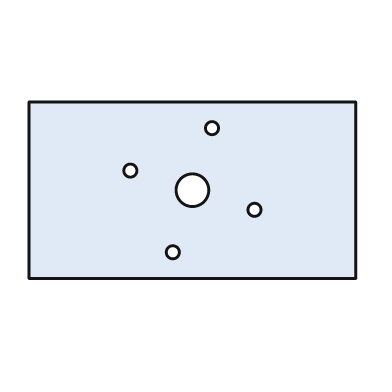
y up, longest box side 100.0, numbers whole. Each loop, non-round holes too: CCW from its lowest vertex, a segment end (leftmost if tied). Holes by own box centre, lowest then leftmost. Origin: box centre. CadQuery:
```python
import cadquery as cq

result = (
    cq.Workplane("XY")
    .moveTo(-50.0, -27.0)
    .lineTo(50.0, -27.0)
    .lineTo(50.0, 27.0)
    .lineTo(-50.0, 27.0)
    .close()
    .moveTo(-6.0, -19.0)
    .circle(2.0)
    .moveTo(19.0, -6.0)
    .circle(2.0)
    .moveTo(0.0, 0.0)
    .circle(5.0)
    .moveTo(-19.0, 6.0)
    .circle(2.0)
    .moveTo(6.0, 19.0)
    .circle(2.0)
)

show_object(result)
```